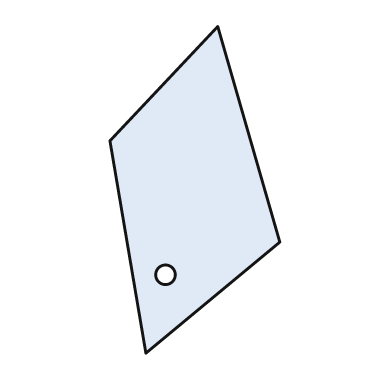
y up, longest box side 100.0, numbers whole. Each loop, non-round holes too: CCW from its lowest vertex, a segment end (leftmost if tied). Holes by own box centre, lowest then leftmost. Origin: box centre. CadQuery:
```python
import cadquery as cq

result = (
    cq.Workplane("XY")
    .moveTo(-15.0, -50.0)
    .lineTo(26.0, -16.0)
    .lineTo(7.0, 50.0)
    .lineTo(-26.0, 15.0)
    .close()
    .moveTo(-9.0, -26.0)
    .circle(3.0)
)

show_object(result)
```